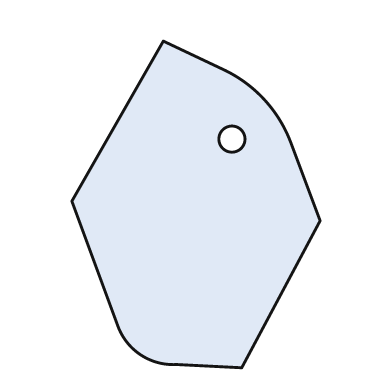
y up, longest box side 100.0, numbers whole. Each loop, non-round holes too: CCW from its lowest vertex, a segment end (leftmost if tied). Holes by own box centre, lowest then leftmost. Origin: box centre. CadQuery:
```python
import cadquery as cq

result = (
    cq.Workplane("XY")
    .moveTo(14.0, -50.0)
    .lineTo(38.0, -5.0)
    .lineTo(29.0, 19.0)
    .threePointArc((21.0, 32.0), (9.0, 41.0))
    .lineTo(-10.0, 50.0)
    .lineTo(-38.0, 1.0)
    .lineTo(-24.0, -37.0)
    .threePointArc((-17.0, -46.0), (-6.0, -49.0))
    .close()
    .moveTo(11.0, 20.0)
    .circle(4.0)
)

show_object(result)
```